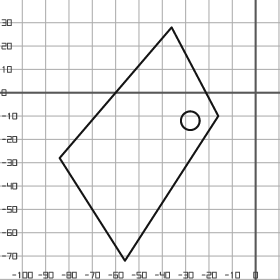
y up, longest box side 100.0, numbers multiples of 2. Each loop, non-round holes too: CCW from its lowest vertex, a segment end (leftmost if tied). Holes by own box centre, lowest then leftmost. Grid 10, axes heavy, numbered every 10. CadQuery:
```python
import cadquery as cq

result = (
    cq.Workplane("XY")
    .moveTo(-56.0, -72.0)
    .lineTo(-16.0, -10.0)
    .lineTo(-36.0, 28.0)
    .lineTo(-84.0, -28.0)
    .close()
    .moveTo(-28.0, -12.0)
    .circle(4.0)
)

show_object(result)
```